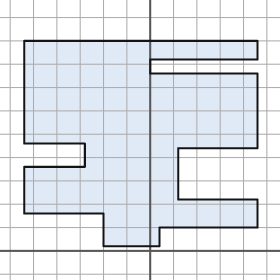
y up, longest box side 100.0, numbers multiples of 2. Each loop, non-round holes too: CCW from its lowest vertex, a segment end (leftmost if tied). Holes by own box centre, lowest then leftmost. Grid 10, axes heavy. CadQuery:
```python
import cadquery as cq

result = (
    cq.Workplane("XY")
    .moveTo(-20.0, 2.0)
    .lineTo(4.0, 2.0)
    .lineTo(4.0, 10.0)
    .lineTo(46.0, 10.0)
    .lineTo(46.0, 22.0)
    .lineTo(12.0, 22.0)
    .lineTo(12.0, 44.0)
    .lineTo(46.0, 44.0)
    .lineTo(46.0, 76.0)
    .lineTo(0.0, 76.0)
    .lineTo(0.0, 82.0)
    .lineTo(46.0, 82.0)
    .lineTo(46.0, 90.0)
    .lineTo(-54.0, 90.0)
    .lineTo(-54.0, 46.0)
    .lineTo(-28.0, 46.0)
    .lineTo(-28.0, 36.0)
    .lineTo(-54.0, 36.0)
    .lineTo(-54.0, 16.0)
    .lineTo(-20.0, 16.0)
    .close()
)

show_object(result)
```